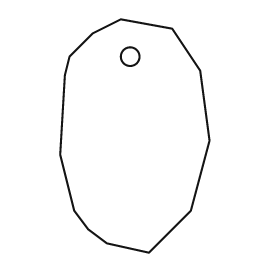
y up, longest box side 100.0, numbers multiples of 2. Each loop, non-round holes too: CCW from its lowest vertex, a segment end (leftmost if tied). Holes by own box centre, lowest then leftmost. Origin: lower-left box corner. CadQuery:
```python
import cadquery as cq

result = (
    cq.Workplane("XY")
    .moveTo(38.0, 0.0)
    .lineTo(56.0, 18.0)
    .lineTo(64.0, 48.0)
    .lineTo(60.0, 78.0)
    .lineTo(48.0, 96.0)
    .lineTo(26.0, 100.0)
    .lineTo(14.0, 94.0)
    .lineTo(4.0, 84.0)
    .lineTo(2.0, 76.0)
    .lineTo(0.0, 42.0)
    .lineTo(6.0, 18.0)
    .lineTo(12.0, 10.0)
    .lineTo(20.0, 4.0)
    .close()
    .moveTo(30.0, 84.0)
    .circle(4.0)
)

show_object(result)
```